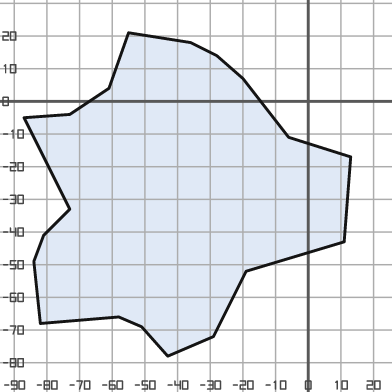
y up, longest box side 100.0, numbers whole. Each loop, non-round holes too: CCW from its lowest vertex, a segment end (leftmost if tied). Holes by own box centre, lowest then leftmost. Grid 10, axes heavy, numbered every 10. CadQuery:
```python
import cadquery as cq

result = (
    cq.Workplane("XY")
    .moveTo(-43.0, -78.0)
    .lineTo(-29.0, -72.0)
    .lineTo(-19.0, -52.0)
    .lineTo(11.0, -43.0)
    .lineTo(13.0, -17.0)
    .lineTo(-6.0, -11.0)
    .lineTo(-20.0, 7.0)
    .lineTo(-28.0, 14.0)
    .lineTo(-36.0, 18.0)
    .lineTo(-55.0, 21.0)
    .lineTo(-61.0, 4.0)
    .lineTo(-73.0, -4.0)
    .lineTo(-87.0, -5.0)
    .lineTo(-73.0, -33.0)
    .lineTo(-81.0, -41.0)
    .lineTo(-84.0, -49.0)
    .lineTo(-82.0, -68.0)
    .lineTo(-58.0, -66.0)
    .lineTo(-51.0, -69.0)
    .close()
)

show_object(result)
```